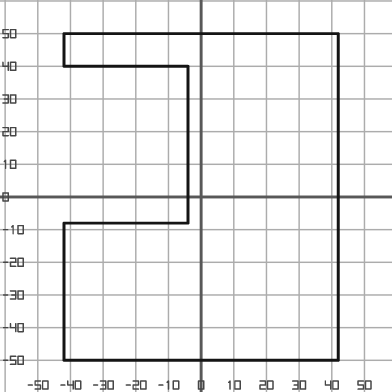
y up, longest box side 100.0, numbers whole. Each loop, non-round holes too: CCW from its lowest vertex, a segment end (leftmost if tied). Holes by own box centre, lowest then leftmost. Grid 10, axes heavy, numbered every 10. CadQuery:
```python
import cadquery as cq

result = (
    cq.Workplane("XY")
    .moveTo(-42.0, -50.0)
    .lineTo(42.0, -50.0)
    .lineTo(42.0, 50.0)
    .lineTo(-42.0, 50.0)
    .lineTo(-42.0, 40.0)
    .lineTo(-4.0, 40.0)
    .lineTo(-4.0, -8.0)
    .lineTo(-42.0, -8.0)
    .close()
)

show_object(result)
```